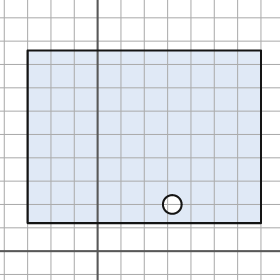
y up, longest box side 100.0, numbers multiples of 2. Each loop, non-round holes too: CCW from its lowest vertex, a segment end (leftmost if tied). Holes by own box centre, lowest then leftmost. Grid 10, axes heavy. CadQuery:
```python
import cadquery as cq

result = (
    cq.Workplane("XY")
    .moveTo(-30.0, 12.0)
    .lineTo(70.0, 12.0)
    .lineTo(70.0, 86.0)
    .lineTo(-30.0, 86.0)
    .close()
    .moveTo(32.0, 20.0)
    .circle(4.0)
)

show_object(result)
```